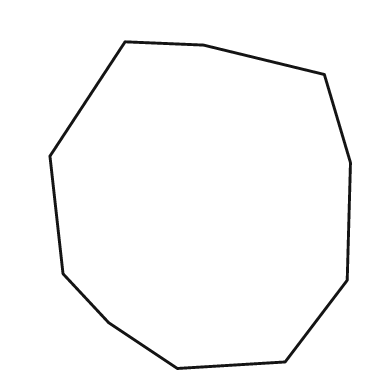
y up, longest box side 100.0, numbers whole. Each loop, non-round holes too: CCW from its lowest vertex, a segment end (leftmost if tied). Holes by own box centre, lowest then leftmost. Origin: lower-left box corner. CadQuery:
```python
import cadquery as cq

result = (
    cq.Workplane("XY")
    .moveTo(39.0, 0.0)
    .lineTo(72.0, 2.0)
    .lineTo(91.0, 27.0)
    .lineTo(92.0, 63.0)
    .lineTo(84.0, 90.0)
    .lineTo(47.0, 99.0)
    .lineTo(23.0, 100.0)
    .lineTo(0.0, 65.0)
    .lineTo(4.0, 29.0)
    .lineTo(18.0, 14.0)
    .close()
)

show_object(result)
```